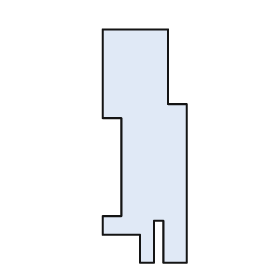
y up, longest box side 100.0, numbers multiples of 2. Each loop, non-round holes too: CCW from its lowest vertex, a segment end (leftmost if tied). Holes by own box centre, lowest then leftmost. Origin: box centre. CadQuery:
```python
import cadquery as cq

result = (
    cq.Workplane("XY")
    .moveTo(-2.0, -50.0)
    .lineTo(4.0, -50.0)
    .lineTo(4.0, -32.0)
    .lineTo(8.0, -32.0)
    .lineTo(8.0, -50.0)
    .lineTo(18.0, -50.0)
    .lineTo(18.0, 18.0)
    .lineTo(10.0, 18.0)
    .lineTo(10.0, 50.0)
    .lineTo(-18.0, 50.0)
    .lineTo(-18.0, 12.0)
    .lineTo(-10.0, 12.0)
    .lineTo(-10.0, -30.0)
    .lineTo(-18.0, -30.0)
    .lineTo(-18.0, -38.0)
    .lineTo(-2.0, -38.0)
    .close()
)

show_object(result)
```